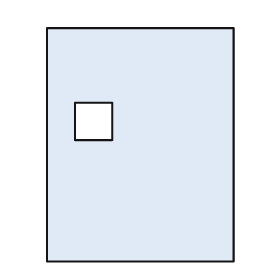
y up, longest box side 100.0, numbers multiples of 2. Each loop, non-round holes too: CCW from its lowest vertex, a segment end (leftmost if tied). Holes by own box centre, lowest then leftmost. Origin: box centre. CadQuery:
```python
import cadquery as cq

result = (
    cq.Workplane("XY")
    .moveTo(-40.0, -50.0)
    .lineTo(40.0, -50.0)
    .lineTo(40.0, 50.0)
    .lineTo(-40.0, 50.0)
    .close()
    .moveTo(-28.0, 2.0)
    .lineTo(-12.0, 2.0)
    .lineTo(-12.0, 18.0)
    .lineTo(-28.0, 18.0)
    .close()
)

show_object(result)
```